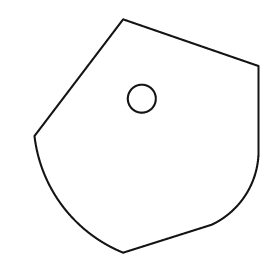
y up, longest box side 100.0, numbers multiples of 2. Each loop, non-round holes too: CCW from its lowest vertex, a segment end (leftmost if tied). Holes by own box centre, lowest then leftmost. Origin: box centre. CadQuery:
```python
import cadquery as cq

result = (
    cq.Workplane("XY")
    .moveTo(-10.0, -50.0)
    .lineTo(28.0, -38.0)
    .threePointArc((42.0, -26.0), (48.0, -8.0))
    .lineTo(48.0, 30.0)
    .lineTo(-10.0, 50.0)
    .lineTo(-48.0, 0.0)
    .threePointArc((-36.0, -30.0), (-10.0, -50.0))
    .close()
    .moveTo(-2.0, 16.0)
    .circle(6.0)
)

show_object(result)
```